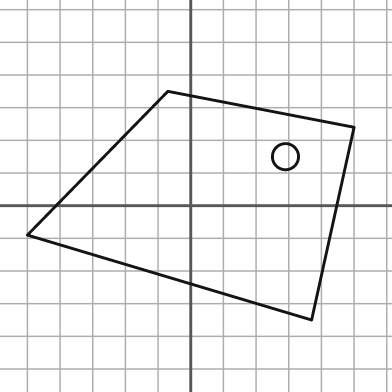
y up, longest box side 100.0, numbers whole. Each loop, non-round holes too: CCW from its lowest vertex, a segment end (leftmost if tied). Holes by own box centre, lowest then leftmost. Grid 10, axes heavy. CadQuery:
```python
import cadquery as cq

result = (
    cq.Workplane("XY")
    .moveTo(37.0, -35.0)
    .lineTo(50.0, 24.0)
    .lineTo(-7.0, 35.0)
    .lineTo(-50.0, -9.0)
    .close()
    .moveTo(29.0, 15.0)
    .circle(4.0)
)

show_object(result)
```